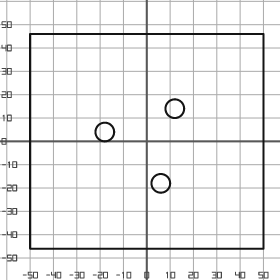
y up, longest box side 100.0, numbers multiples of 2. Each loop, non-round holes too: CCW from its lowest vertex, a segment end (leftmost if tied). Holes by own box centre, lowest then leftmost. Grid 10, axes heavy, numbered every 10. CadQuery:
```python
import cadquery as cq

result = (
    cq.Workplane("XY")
    .moveTo(-50.0, -46.0)
    .lineTo(50.0, -46.0)
    .lineTo(50.0, 46.0)
    .lineTo(-50.0, 46.0)
    .close()
    .moveTo(6.0, -18.0)
    .circle(4.0)
    .moveTo(-18.0, 4.0)
    .circle(4.0)
    .moveTo(12.0, 14.0)
    .circle(4.0)
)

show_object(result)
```